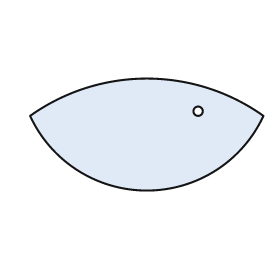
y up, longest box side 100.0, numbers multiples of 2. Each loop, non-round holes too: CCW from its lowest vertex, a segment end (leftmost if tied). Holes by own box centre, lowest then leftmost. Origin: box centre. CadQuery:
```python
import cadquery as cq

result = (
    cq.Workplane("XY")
    .moveTo(-50.0, 8.0)
    .threePointArc((0.0, -24.0), (50.0, 8.0))
    .threePointArc((0.0, 24.0), (-50.0, 8.0))
    .close()
    .moveTo(22.0, 10.0)
    .circle(2.0)
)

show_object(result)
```